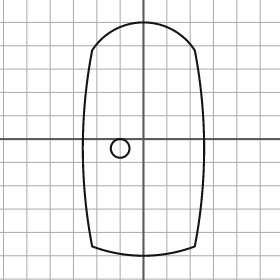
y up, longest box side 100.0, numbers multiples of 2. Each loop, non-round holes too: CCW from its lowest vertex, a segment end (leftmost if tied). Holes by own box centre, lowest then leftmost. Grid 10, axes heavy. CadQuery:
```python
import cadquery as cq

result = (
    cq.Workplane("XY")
    .moveTo(-22.0, -46.0)
    .threePointArc((0.0, -50.0), (22.0, -46.0))
    .threePointArc((26.0, -4.0), (22.0, 38.0))
    .threePointArc((0.0, 50.0), (-22.0, 38.0))
    .threePointArc((-26.0, -4.0), (-22.0, -46.0))
    .close()
    .moveTo(-10.0, -4.0)
    .circle(4.0)
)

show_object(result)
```